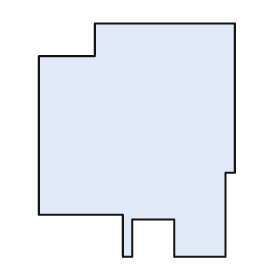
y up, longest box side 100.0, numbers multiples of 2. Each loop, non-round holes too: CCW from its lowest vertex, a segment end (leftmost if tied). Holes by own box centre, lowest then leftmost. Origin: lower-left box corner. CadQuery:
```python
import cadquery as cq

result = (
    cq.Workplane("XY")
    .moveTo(36.0, 0.0)
    .lineTo(40.0, 0.0)
    .lineTo(40.0, 16.0)
    .lineTo(58.0, 16.0)
    .lineTo(58.0, 0.0)
    .lineTo(80.0, 0.0)
    .lineTo(80.0, 36.0)
    .lineTo(84.0, 36.0)
    .lineTo(84.0, 100.0)
    .lineTo(24.0, 100.0)
    .lineTo(24.0, 86.0)
    .lineTo(0.0, 86.0)
    .lineTo(0.0, 18.0)
    .lineTo(36.0, 18.0)
    .close()
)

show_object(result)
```